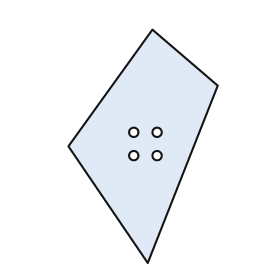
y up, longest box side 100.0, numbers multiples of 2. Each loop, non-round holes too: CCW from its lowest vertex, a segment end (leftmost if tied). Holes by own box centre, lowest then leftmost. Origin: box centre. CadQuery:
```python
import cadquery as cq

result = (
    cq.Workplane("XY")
    .moveTo(2.0, -50.0)
    .lineTo(32.0, 26.0)
    .lineTo(4.0, 50.0)
    .lineTo(-32.0, 0.0)
    .close()
    .moveTo(-4.0, -4.0)
    .circle(2.0)
    .moveTo(6.0, -4.0)
    .circle(2.0)
    .moveTo(-4.0, 6.0)
    .circle(2.0)
    .moveTo(6.0, 6.0)
    .circle(2.0)
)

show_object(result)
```